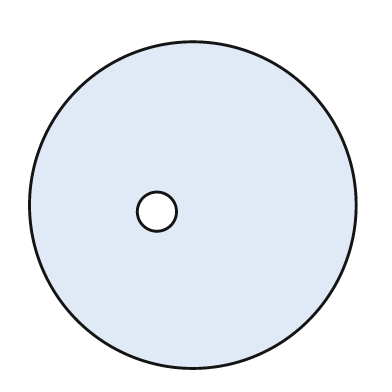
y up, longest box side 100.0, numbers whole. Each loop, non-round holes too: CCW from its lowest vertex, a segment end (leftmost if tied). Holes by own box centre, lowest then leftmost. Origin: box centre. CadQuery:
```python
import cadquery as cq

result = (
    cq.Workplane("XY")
    .moveTo(0.0, 0.0)
    .circle(50.0)
    .moveTo(-11.0, -2.0)
    .circle(6.0)
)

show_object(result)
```